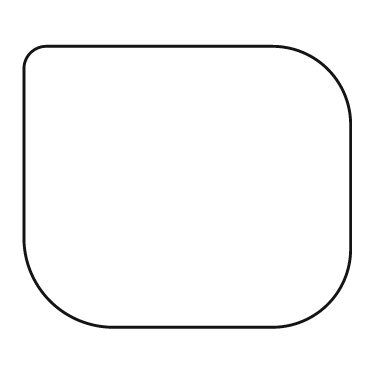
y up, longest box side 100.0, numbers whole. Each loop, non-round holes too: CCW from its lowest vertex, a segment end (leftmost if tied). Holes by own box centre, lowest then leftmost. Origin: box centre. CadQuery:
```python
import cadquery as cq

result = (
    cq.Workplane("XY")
    .moveTo(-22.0, -43.0)
    .lineTo(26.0, -43.0)
    .threePointArc((43.0, -36.0), (50.0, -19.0))
    .lineTo(50.0, 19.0)
    .threePointArc((43.0, 36.0), (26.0, 43.0))
    .lineTo(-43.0, 43.0)
    .threePointArc((-48.0, 41.0), (-50.0, 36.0))
    .lineTo(-50.0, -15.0)
    .threePointArc((-42.0, -35.0), (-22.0, -43.0))
    .close()
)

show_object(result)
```